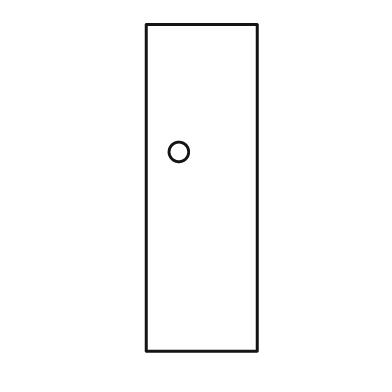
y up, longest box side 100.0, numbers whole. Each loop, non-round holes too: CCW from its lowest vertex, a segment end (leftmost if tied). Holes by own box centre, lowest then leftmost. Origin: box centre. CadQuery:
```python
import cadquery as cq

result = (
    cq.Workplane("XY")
    .moveTo(-17.0, -50.0)
    .lineTo(17.0, -50.0)
    .lineTo(17.0, 50.0)
    .lineTo(-17.0, 50.0)
    .close()
    .moveTo(-7.0, 11.0)
    .circle(3.0)
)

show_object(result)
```